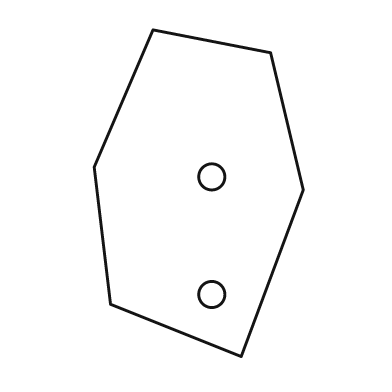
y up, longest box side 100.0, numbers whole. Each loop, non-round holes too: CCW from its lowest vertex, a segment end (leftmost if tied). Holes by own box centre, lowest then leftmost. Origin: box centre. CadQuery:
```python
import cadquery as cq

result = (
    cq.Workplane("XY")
    .moveTo(13.0, -50.0)
    .lineTo(32.0, 1.0)
    .lineTo(22.0, 43.0)
    .lineTo(-14.0, 50.0)
    .lineTo(-32.0, 8.0)
    .lineTo(-27.0, -34.0)
    .close()
    .moveTo(4.0, -31.0)
    .circle(4.0)
    .moveTo(4.0, 5.0)
    .circle(4.0)
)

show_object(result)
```